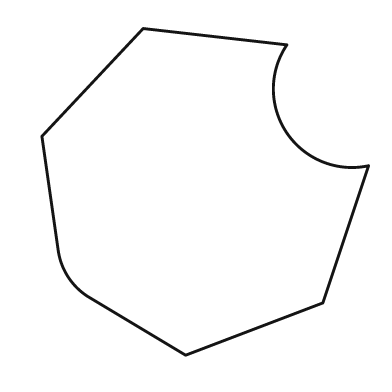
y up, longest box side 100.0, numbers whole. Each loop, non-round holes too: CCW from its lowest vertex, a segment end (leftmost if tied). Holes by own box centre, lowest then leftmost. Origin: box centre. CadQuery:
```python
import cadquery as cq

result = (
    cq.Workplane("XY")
    .moveTo(-6.0, -50.0)
    .lineTo(36.0, -34.0)
    .lineTo(50.0, 8.0)
    .threePointArc((25.0, 18.0), (25.0, 45.0))
    .lineTo(-19.0, 50.0)
    .lineTo(-50.0, 17.0)
    .lineTo(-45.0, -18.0)
    .threePointArc((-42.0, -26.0), (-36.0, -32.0))
    .close()
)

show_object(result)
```